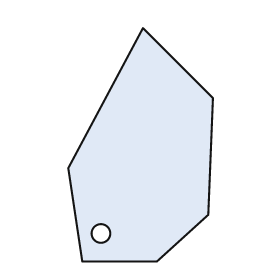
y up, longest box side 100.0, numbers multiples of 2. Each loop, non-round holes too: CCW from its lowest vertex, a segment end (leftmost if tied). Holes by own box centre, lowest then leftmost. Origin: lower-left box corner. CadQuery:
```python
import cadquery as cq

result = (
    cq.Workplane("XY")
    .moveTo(6.0, 0.0)
    .lineTo(38.0, 0.0)
    .lineTo(60.0, 20.0)
    .lineTo(62.0, 70.0)
    .lineTo(32.0, 100.0)
    .lineTo(0.0, 40.0)
    .close()
    .moveTo(14.0, 12.0)
    .circle(4.0)
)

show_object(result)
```